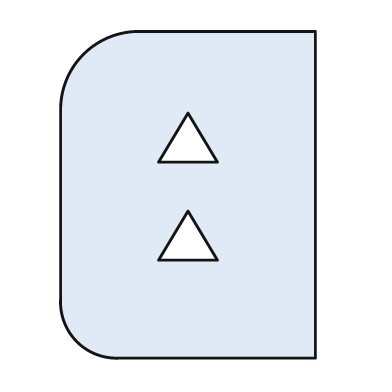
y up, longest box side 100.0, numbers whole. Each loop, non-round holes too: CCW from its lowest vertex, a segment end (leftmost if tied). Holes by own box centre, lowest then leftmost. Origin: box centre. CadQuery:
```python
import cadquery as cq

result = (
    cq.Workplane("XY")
    .moveTo(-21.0, -50.0)
    .lineTo(39.0, -50.0)
    .lineTo(39.0, 50.0)
    .lineTo(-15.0, 50.0)
    .threePointArc((-32.0, 43.0), (-39.0, 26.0))
    .lineTo(-39.0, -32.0)
    .threePointArc((-34.0, -45.0), (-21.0, -50.0))
    .close()
    .moveTo(-9.0, -20.0)
    .lineTo(9.0, -20.0)
    .lineTo(0.0, -5.0)
    .close()
    .moveTo(-9.0, 10.0)
    .lineTo(9.0, 10.0)
    .lineTo(0.0, 25.0)
    .close()
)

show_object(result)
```